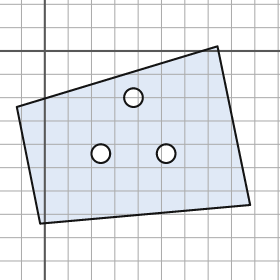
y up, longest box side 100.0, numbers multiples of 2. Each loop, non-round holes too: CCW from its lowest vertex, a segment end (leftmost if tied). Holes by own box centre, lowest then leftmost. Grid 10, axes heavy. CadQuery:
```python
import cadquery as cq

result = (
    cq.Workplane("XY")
    .moveTo(-2.0, -74.0)
    .lineTo(88.0, -66.0)
    .lineTo(74.0, 2.0)
    .lineTo(-12.0, -24.0)
    .close()
    .moveTo(24.0, -44.0)
    .circle(4.0)
    .moveTo(52.0, -44.0)
    .circle(4.0)
    .moveTo(38.0, -20.0)
    .circle(4.0)
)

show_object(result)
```